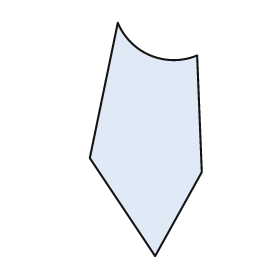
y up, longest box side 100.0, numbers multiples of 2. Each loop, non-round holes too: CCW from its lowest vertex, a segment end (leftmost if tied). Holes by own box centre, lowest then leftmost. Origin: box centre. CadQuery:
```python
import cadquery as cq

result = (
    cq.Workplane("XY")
    .moveTo(4.0, -50.0)
    .lineTo(24.0, -14.0)
    .lineTo(22.0, 36.0)
    .threePointArc((2.0, 36.0), (-12.0, 50.0))
    .lineTo(-24.0, -8.0)
    .close()
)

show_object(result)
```